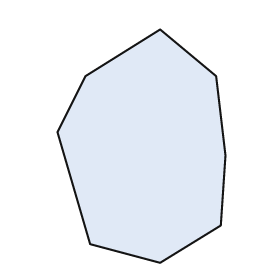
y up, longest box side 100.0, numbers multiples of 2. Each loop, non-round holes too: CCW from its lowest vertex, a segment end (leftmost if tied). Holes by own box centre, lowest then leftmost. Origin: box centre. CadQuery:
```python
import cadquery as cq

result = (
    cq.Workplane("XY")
    .moveTo(8.0, -50.0)
    .lineTo(34.0, -34.0)
    .lineTo(36.0, -4.0)
    .lineTo(32.0, 30.0)
    .lineTo(8.0, 50.0)
    .lineTo(-24.0, 30.0)
    .lineTo(-36.0, 6.0)
    .lineTo(-22.0, -42.0)
    .close()
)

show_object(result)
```